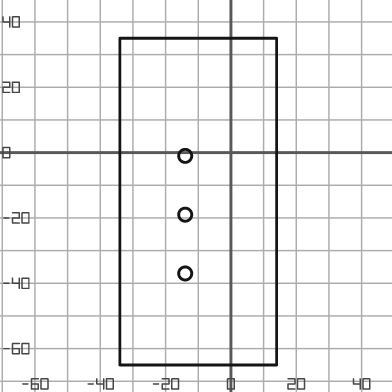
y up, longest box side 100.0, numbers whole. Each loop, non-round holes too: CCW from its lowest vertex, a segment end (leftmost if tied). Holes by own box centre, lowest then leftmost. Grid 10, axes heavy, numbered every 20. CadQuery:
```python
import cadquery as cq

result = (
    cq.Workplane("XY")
    .moveTo(-34.0, -65.0)
    .lineTo(14.0, -65.0)
    .lineTo(14.0, 35.0)
    .lineTo(-34.0, 35.0)
    .close()
    .moveTo(-14.0, -37.0)
    .circle(2.0)
    .moveTo(-14.0, -19.0)
    .circle(2.0)
    .moveTo(-14.0, -1.0)
    .circle(2.0)
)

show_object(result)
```